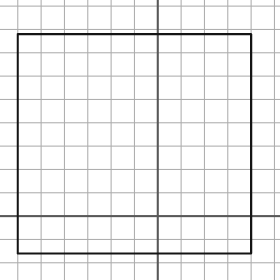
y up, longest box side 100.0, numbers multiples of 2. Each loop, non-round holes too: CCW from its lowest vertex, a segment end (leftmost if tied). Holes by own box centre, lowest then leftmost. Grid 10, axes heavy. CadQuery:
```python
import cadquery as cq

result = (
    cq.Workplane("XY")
    .moveTo(-60.0, -16.0)
    .lineTo(40.0, -16.0)
    .lineTo(40.0, 78.0)
    .lineTo(-60.0, 78.0)
    .close()
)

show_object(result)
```